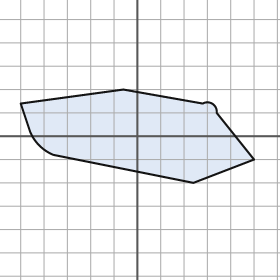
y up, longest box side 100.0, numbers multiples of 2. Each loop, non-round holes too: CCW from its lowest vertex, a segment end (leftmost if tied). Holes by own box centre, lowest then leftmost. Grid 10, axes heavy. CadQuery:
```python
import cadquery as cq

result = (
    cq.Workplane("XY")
    .moveTo(24.0, -20.0)
    .lineTo(50.0, -10.0)
    .lineTo(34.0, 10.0)
    .threePointArc((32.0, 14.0), (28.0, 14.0))
    .lineTo(-6.0, 20.0)
    .lineTo(-50.0, 14.0)
    .lineTo(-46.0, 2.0)
    .threePointArc((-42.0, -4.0), (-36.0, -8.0))
    .close()
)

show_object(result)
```